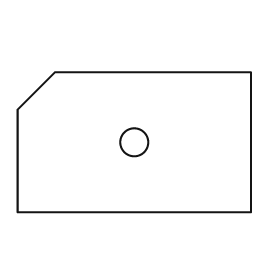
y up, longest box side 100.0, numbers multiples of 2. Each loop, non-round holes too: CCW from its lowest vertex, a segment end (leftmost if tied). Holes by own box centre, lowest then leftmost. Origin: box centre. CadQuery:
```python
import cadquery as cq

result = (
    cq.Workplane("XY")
    .moveTo(-50.0, -30.0)
    .lineTo(50.0, -30.0)
    .lineTo(50.0, 30.0)
    .lineTo(-34.0, 30.0)
    .lineTo(-50.0, 14.0)
    .close()
    .moveTo(0.0, 0.0)
    .circle(6.0)
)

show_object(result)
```